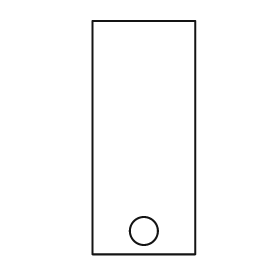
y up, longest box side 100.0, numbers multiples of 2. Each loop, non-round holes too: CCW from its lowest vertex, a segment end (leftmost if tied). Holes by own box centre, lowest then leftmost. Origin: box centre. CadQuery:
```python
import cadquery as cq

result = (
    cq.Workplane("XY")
    .moveTo(-22.0, -50.0)
    .lineTo(22.0, -50.0)
    .lineTo(22.0, 50.0)
    .lineTo(-22.0, 50.0)
    .close()
    .moveTo(0.0, -40.0)
    .circle(6.0)
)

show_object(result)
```